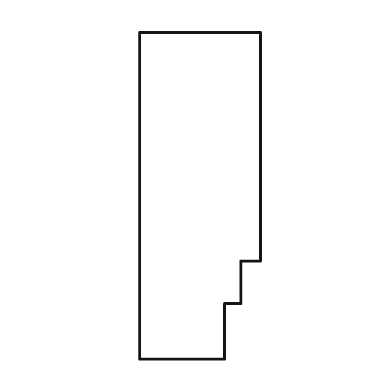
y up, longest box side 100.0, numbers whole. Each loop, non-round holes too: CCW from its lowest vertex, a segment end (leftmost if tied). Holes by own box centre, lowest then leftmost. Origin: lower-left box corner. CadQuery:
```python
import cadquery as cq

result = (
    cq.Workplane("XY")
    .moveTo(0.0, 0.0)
    .lineTo(26.0, 0.0)
    .lineTo(26.0, 17.0)
    .lineTo(31.0, 17.0)
    .lineTo(31.0, 30.0)
    .lineTo(37.0, 30.0)
    .lineTo(37.0, 100.0)
    .lineTo(0.0, 100.0)
    .close()
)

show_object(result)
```